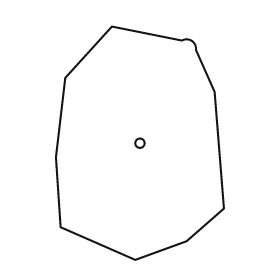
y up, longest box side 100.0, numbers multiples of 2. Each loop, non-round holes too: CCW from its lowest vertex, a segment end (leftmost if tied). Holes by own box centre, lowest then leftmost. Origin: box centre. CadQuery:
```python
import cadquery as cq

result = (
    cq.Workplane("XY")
    .moveTo(-2.0, -50.0)
    .lineTo(20.0, -42.0)
    .lineTo(36.0, -28.0)
    .lineTo(32.0, 22.0)
    .lineTo(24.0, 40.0)
    .threePointArc((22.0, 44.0), (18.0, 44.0))
    .lineTo(-12.0, 50.0)
    .lineTo(-32.0, 28.0)
    .lineTo(-36.0, -6.0)
    .lineTo(-34.0, -36.0)
    .close()
    .moveTo(0.0, 0.0)
    .circle(2.0)
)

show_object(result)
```